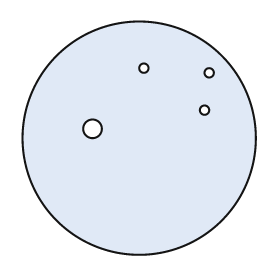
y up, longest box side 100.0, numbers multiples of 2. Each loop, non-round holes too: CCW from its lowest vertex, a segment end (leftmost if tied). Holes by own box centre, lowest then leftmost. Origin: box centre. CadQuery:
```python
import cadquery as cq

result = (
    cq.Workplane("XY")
    .moveTo(0.0, 0.0)
    .circle(50.0)
    .moveTo(-20.0, 4.0)
    .circle(4.0)
    .moveTo(28.0, 12.0)
    .circle(2.0)
    .moveTo(30.0, 28.0)
    .circle(2.0)
    .moveTo(2.0, 30.0)
    .circle(2.0)
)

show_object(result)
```